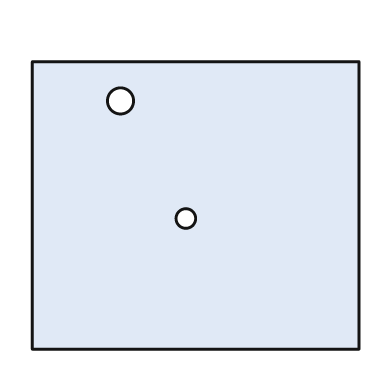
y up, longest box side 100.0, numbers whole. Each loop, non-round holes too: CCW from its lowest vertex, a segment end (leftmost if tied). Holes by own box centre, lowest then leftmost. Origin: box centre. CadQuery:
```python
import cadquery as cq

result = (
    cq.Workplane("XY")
    .moveTo(-50.0, -44.0)
    .lineTo(50.0, -44.0)
    .lineTo(50.0, 44.0)
    .lineTo(-50.0, 44.0)
    .close()
    .moveTo(-3.0, -4.0)
    .circle(3.0)
    .moveTo(-23.0, 32.0)
    .circle(4.0)
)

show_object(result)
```